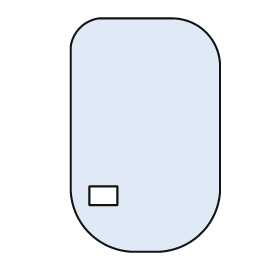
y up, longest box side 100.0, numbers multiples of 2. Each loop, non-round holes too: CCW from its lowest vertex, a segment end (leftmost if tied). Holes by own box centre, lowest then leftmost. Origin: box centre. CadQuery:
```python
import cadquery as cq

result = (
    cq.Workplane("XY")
    .moveTo(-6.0, -50.0)
    .lineTo(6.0, -50.0)
    .threePointArc((24.0, -42.0), (32.0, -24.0))
    .lineTo(32.0, 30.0)
    .threePointArc((26.0, 44.0), (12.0, 50.0))
    .lineTo(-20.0, 50.0)
    .threePointArc((-28.0, 46.0), (-32.0, 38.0))
    .lineTo(-32.0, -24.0)
    .threePointArc((-24.0, -42.0), (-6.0, -50.0))
    .close()
    .moveTo(-24.0, -30.0)
    .lineTo(-12.0, -30.0)
    .lineTo(-12.0, -22.0)
    .lineTo(-24.0, -22.0)
    .close()
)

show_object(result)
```